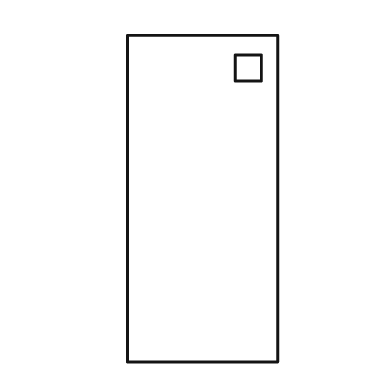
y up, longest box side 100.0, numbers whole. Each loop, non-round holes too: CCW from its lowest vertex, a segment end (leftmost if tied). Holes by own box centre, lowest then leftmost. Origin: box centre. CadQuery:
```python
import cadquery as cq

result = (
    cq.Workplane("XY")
    .moveTo(-23.0, -50.0)
    .lineTo(23.0, -50.0)
    .lineTo(23.0, 50.0)
    .lineTo(-23.0, 50.0)
    .close()
    .moveTo(10.0, 36.0)
    .lineTo(18.0, 36.0)
    .lineTo(18.0, 44.0)
    .lineTo(10.0, 44.0)
    .close()
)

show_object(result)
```